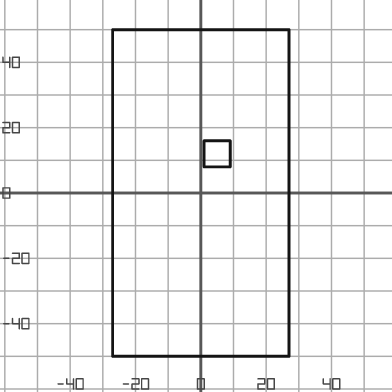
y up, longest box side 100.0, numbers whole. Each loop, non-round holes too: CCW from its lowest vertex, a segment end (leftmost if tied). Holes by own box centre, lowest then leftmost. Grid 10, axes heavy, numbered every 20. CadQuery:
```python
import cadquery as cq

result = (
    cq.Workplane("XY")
    .moveTo(-27.0, -50.0)
    .lineTo(27.0, -50.0)
    .lineTo(27.0, 50.0)
    .lineTo(-27.0, 50.0)
    .close()
    .moveTo(1.0, 8.0)
    .lineTo(9.0, 8.0)
    .lineTo(9.0, 16.0)
    .lineTo(1.0, 16.0)
    .close()
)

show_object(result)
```